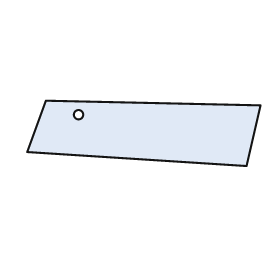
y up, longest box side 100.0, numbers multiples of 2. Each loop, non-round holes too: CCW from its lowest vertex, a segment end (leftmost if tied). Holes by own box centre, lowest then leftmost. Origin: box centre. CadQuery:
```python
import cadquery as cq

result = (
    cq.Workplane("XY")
    .moveTo(44.0, -14.0)
    .lineTo(50.0, 12.0)
    .lineTo(-42.0, 14.0)
    .lineTo(-50.0, -8.0)
    .close()
    .moveTo(-28.0, 8.0)
    .circle(2.0)
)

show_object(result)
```